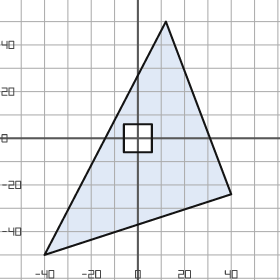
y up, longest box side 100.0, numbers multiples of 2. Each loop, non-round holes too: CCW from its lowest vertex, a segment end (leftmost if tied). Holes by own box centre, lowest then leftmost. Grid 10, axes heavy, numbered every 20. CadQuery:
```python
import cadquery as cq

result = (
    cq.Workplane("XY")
    .moveTo(-40.0, -50.0)
    .lineTo(40.0, -24.0)
    .lineTo(12.0, 50.0)
    .close()
    .moveTo(-6.0, -6.0)
    .lineTo(6.0, -6.0)
    .lineTo(6.0, 6.0)
    .lineTo(-6.0, 6.0)
    .close()
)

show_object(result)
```